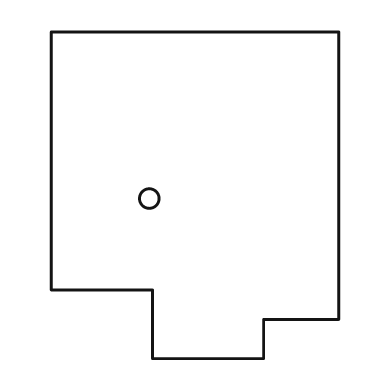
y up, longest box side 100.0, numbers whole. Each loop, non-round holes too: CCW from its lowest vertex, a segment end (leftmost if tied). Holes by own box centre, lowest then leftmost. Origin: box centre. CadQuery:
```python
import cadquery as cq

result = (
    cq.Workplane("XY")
    .moveTo(-13.0, -50.0)
    .lineTo(21.0, -50.0)
    .lineTo(21.0, -38.0)
    .lineTo(44.0, -38.0)
    .lineTo(44.0, 50.0)
    .lineTo(-44.0, 50.0)
    .lineTo(-44.0, -29.0)
    .lineTo(-13.0, -29.0)
    .close()
    .moveTo(-14.0, -1.0)
    .circle(3.0)
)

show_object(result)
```